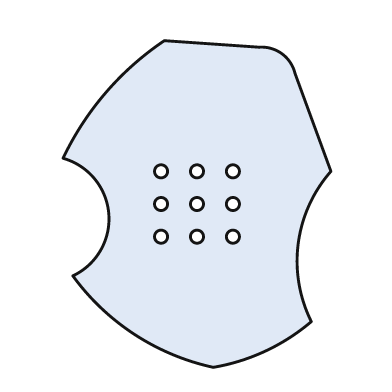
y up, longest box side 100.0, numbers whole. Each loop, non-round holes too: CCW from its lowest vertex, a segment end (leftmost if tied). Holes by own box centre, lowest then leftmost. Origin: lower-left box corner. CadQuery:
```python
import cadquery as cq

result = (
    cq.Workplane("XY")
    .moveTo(46.0, 0.0)
    .threePointArc((62.0, 5.0), (76.0, 14.0))
    .threePointArc((72.0, 38.0), (82.0, 60.0))
    .lineTo(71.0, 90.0)
    .threePointArc((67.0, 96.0), (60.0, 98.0))
    .lineTo(31.0, 100.0)
    .threePointArc((13.0, 84.0), (0.0, 64.0))
    .threePointArc((14.0, 47.0), (3.0, 28.0))
    .threePointArc((22.0, 10.0), (46.0, 0.0))
    .close()
    .moveTo(30.0, 40.0)
    .circle(2.0)
    .moveTo(41.0, 40.0)
    .circle(2.0)
    .moveTo(52.0, 40.0)
    .circle(2.0)
    .moveTo(30.0, 50.0)
    .circle(2.0)
    .moveTo(41.0, 50.0)
    .circle(2.0)
    .moveTo(52.0, 50.0)
    .circle(2.0)
    .moveTo(30.0, 60.0)
    .circle(2.0)
    .moveTo(41.0, 60.0)
    .circle(2.0)
    .moveTo(52.0, 60.0)
    .circle(2.0)
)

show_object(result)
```